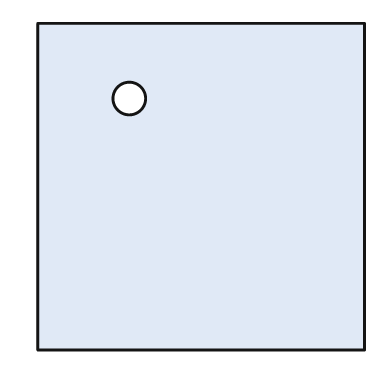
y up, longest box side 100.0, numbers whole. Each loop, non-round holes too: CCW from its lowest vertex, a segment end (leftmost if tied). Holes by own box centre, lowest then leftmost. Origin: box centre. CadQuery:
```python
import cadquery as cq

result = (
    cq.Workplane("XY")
    .moveTo(-50.0, -50.0)
    .lineTo(50.0, -50.0)
    .lineTo(50.0, 50.0)
    .lineTo(-50.0, 50.0)
    .close()
    .moveTo(-22.0, 27.0)
    .circle(5.0)
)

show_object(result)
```